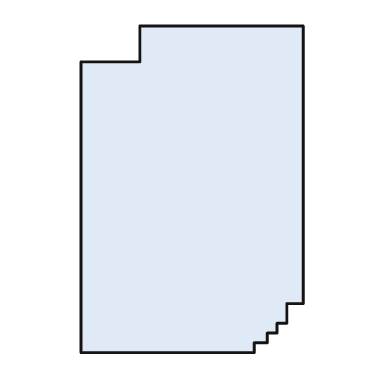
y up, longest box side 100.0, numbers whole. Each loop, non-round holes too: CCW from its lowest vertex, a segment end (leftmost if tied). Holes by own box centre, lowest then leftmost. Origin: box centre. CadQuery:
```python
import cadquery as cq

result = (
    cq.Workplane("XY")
    .moveTo(-34.0, -50.0)
    .lineTo(19.0, -50.0)
    .lineTo(19.0, -47.0)
    .lineTo(23.0, -47.0)
    .lineTo(23.0, -44.0)
    .lineTo(26.0, -44.0)
    .lineTo(26.0, -41.0)
    .lineTo(29.0, -41.0)
    .lineTo(29.0, -35.0)
    .lineTo(34.0, -35.0)
    .lineTo(34.0, 50.0)
    .lineTo(-16.0, 50.0)
    .lineTo(-16.0, 39.0)
    .lineTo(-34.0, 39.0)
    .close()
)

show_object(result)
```